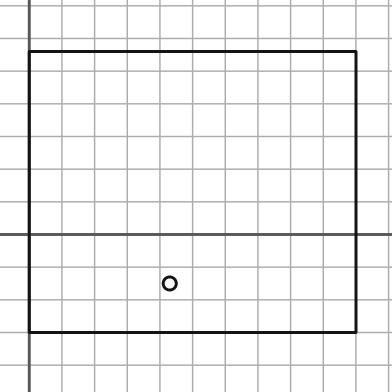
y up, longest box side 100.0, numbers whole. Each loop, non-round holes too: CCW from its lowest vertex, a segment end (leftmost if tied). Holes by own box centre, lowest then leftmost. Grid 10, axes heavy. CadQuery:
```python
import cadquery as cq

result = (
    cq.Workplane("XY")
    .moveTo(0.0, -30.0)
    .lineTo(100.0, -30.0)
    .lineTo(100.0, 56.0)
    .lineTo(0.0, 56.0)
    .close()
    .moveTo(43.0, -15.0)
    .circle(2.0)
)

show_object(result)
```